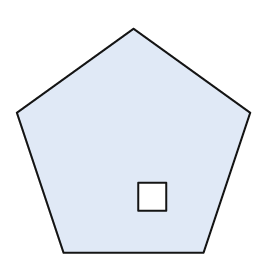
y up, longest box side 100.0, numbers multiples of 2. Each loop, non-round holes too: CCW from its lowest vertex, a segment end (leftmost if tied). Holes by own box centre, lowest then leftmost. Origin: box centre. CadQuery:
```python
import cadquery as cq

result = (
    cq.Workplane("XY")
    .moveTo(-30.0, -48.0)
    .lineTo(30.0, -48.0)
    .lineTo(50.0, 12.0)
    .lineTo(0.0, 48.0)
    .lineTo(-50.0, 12.0)
    .close()
    .moveTo(2.0, -30.0)
    .lineTo(14.0, -30.0)
    .lineTo(14.0, -18.0)
    .lineTo(2.0, -18.0)
    .close()
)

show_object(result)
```